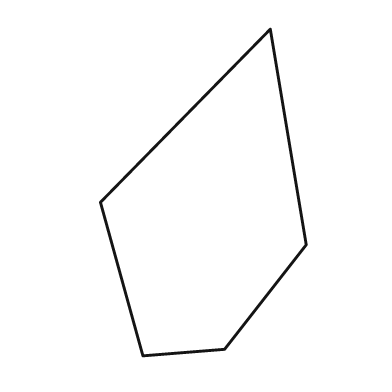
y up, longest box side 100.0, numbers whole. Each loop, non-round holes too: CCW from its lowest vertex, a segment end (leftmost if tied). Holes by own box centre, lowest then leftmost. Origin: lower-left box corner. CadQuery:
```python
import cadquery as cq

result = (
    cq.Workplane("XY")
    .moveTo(13.0, 0.0)
    .lineTo(38.0, 2.0)
    .lineTo(63.0, 34.0)
    .lineTo(52.0, 100.0)
    .lineTo(0.0, 47.0)
    .close()
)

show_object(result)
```